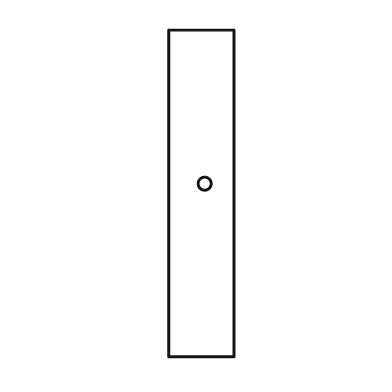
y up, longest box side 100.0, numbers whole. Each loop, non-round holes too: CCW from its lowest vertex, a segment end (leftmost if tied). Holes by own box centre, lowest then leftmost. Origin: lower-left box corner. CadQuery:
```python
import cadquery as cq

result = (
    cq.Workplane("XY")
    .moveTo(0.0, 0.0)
    .lineTo(20.0, 0.0)
    .lineTo(20.0, 100.0)
    .lineTo(0.0, 100.0)
    .close()
    .moveTo(11.0, 53.0)
    .circle(2.0)
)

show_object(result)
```